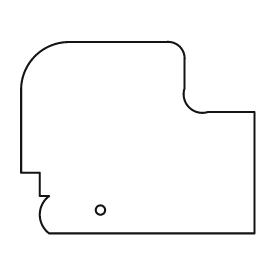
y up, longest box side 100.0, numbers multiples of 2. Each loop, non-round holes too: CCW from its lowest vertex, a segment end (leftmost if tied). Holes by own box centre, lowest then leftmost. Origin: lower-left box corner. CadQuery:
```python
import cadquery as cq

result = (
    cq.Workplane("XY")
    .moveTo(12.0, 0.0)
    .lineTo(100.0, 0.0)
    .lineTo(100.0, 52.0)
    .lineTo(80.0, 52.0)
    .threePointArc((72.0, 54.0), (70.0, 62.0))
    .lineTo(70.0, 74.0)
    .threePointArc((68.0, 80.0), (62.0, 82.0))
    .lineTo(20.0, 82.0)
    .threePointArc((6.0, 76.0), (0.0, 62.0))
    .lineTo(0.0, 26.0)
    .lineTo(8.0, 26.0)
    .lineTo(8.0, 16.0)
    .lineTo(12.0, 16.0)
    .threePointArc((8.0, 8.0), (12.0, 0.0))
    .close()
    .moveTo(34.0, 10.0)
    .circle(2.0)
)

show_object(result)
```